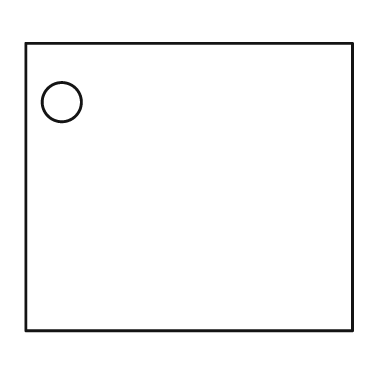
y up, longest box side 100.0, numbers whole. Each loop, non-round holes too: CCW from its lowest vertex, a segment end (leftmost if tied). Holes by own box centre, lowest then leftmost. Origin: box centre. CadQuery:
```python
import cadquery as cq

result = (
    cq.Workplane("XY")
    .moveTo(-50.0, -44.0)
    .lineTo(50.0, -44.0)
    .lineTo(50.0, 44.0)
    .lineTo(-50.0, 44.0)
    .close()
    .moveTo(-39.0, 26.0)
    .circle(6.0)
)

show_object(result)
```